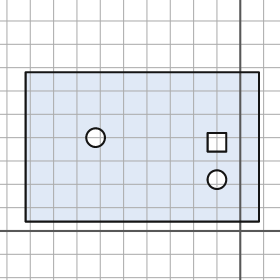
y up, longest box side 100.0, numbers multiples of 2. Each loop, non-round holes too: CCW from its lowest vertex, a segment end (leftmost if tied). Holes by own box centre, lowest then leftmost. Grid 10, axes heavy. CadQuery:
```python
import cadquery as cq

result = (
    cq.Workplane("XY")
    .moveTo(-92.0, 4.0)
    .lineTo(8.0, 4.0)
    .lineTo(8.0, 68.0)
    .lineTo(-92.0, 68.0)
    .close()
    .moveTo(-10.0, 22.0)
    .circle(4.0)
    .moveTo(-14.0, 34.0)
    .lineTo(-6.0, 34.0)
    .lineTo(-6.0, 42.0)
    .lineTo(-14.0, 42.0)
    .close()
    .moveTo(-62.0, 40.0)
    .circle(4.0)
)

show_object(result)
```